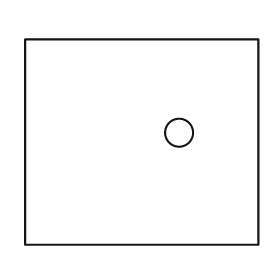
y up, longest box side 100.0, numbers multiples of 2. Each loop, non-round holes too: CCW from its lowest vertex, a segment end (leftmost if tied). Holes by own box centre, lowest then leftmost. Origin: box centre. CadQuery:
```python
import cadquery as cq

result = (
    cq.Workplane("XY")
    .moveTo(-50.0, -44.0)
    .lineTo(50.0, -44.0)
    .lineTo(50.0, 44.0)
    .lineTo(-50.0, 44.0)
    .close()
    .moveTo(16.0, 4.0)
    .circle(6.0)
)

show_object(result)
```